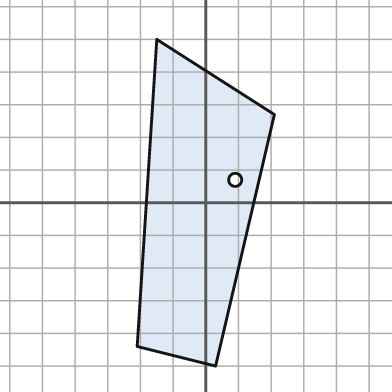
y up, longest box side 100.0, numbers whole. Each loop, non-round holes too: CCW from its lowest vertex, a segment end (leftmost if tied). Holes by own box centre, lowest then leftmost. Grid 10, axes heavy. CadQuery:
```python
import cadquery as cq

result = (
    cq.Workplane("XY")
    .moveTo(3.0, -50.0)
    .lineTo(21.0, 27.0)
    .lineTo(-15.0, 50.0)
    .lineTo(-21.0, -44.0)
    .close()
    .moveTo(9.0, 7.0)
    .circle(2.0)
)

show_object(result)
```